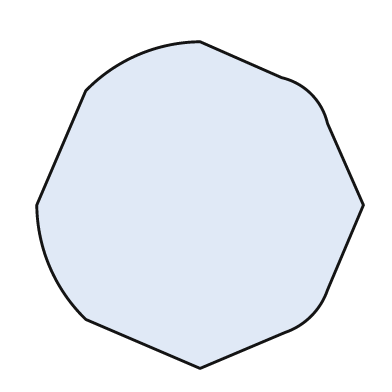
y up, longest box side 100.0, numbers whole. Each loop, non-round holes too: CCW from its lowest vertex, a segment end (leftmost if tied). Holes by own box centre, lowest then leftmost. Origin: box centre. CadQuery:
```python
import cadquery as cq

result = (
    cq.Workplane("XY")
    .moveTo(0.0, -50.0)
    .lineTo(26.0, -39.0)
    .threePointArc((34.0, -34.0), (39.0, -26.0))
    .lineTo(50.0, 0.0)
    .lineTo(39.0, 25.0)
    .threePointArc((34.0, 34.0), (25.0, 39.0))
    .lineTo(0.0, 50.0)
    .threePointArc((-19.0, 46.0), (-35.0, 35.0))
    .lineTo(-50.0, 0.0)
    .threePointArc((-46.0, -19.0), (-35.0, -35.0))
    .close()
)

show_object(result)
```